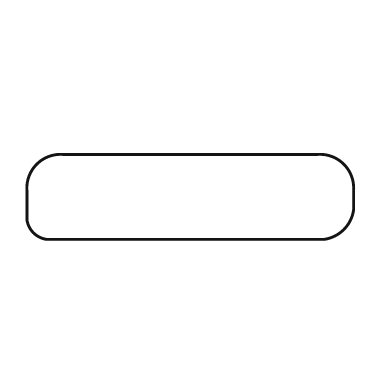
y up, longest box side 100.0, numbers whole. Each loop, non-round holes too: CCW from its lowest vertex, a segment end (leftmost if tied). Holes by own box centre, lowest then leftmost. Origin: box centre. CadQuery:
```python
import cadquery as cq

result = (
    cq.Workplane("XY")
    .moveTo(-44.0, -13.0)
    .lineTo(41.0, -13.0)
    .threePointArc((47.0, -10.0), (50.0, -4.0))
    .lineTo(50.0, 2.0)
    .threePointArc((47.0, 10.0), (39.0, 13.0))
    .lineTo(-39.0, 13.0)
    .threePointArc((-47.0, 10.0), (-50.0, 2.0))
    .lineTo(-50.0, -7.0)
    .threePointArc((-48.0, -11.0), (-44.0, -13.0))
    .close()
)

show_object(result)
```